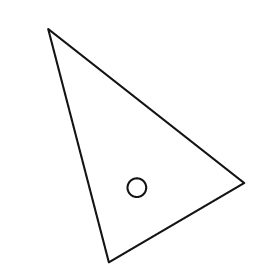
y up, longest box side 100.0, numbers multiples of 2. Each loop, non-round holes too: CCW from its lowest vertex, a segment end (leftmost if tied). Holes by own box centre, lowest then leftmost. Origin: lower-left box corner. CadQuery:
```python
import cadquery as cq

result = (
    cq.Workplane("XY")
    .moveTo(26.0, 0.0)
    .lineTo(84.0, 34.0)
    .lineTo(0.0, 100.0)
    .close()
    .moveTo(38.0, 32.0)
    .circle(4.0)
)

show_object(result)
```